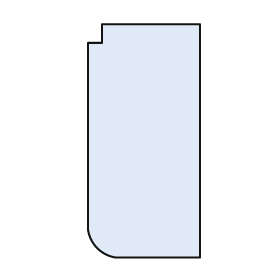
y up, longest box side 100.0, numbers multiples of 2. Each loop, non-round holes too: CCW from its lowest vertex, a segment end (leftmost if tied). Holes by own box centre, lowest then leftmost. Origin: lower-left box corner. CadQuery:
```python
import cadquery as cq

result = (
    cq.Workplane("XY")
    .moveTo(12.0, 0.0)
    .lineTo(48.0, 0.0)
    .lineTo(48.0, 100.0)
    .lineTo(6.0, 100.0)
    .lineTo(6.0, 92.0)
    .lineTo(0.0, 92.0)
    .lineTo(0.0, 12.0)
    .threePointArc((4.0, 4.0), (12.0, 0.0))
    .close()
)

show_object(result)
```